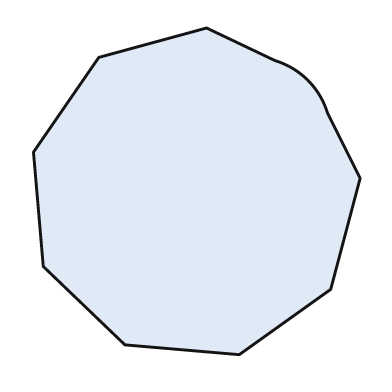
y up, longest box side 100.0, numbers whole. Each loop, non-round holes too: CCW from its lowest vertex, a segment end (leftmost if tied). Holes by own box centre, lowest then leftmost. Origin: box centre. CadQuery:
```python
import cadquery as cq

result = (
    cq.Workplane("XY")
    .moveTo(13.0, -50.0)
    .lineTo(41.0, -30.0)
    .lineTo(50.0, 4.0)
    .lineTo(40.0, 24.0)
    .threePointArc((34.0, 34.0), (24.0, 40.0))
    .lineTo(3.0, 50.0)
    .lineTo(-30.0, 41.0)
    .lineTo(-50.0, 12.0)
    .lineTo(-47.0, -23.0)
    .lineTo(-22.0, -47.0)
    .close()
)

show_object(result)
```